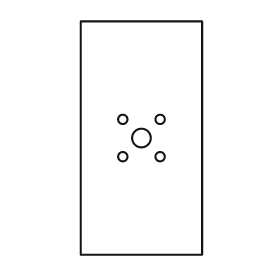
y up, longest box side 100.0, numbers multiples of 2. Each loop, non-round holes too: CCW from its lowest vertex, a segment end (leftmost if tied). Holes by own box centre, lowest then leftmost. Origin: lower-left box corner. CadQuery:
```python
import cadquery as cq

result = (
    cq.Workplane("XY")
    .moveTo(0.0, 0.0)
    .lineTo(52.0, 0.0)
    .lineTo(52.0, 100.0)
    .lineTo(0.0, 100.0)
    .close()
    .moveTo(18.0, 42.0)
    .circle(2.0)
    .moveTo(34.0, 42.0)
    .circle(2.0)
    .moveTo(26.0, 50.0)
    .circle(4.0)
    .moveTo(18.0, 58.0)
    .circle(2.0)
    .moveTo(34.0, 58.0)
    .circle(2.0)
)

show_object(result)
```